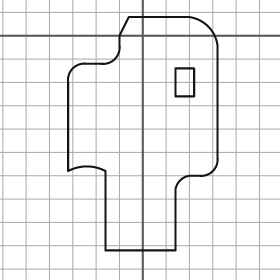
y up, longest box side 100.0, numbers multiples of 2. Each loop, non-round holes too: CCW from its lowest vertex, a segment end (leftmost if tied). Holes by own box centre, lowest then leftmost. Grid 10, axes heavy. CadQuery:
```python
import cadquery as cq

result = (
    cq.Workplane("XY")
    .moveTo(-16.0, -92.0)
    .lineTo(14.0, -92.0)
    .lineTo(14.0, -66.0)
    .threePointArc((16.0, -62.0), (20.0, -60.0))
    .lineTo(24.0, -60.0)
    .threePointArc((30.0, -58.0), (32.0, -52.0))
    .lineTo(32.0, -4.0)
    .threePointArc((28.0, 4.0), (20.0, 8.0))
    .lineTo(-6.0, 8.0)
    .lineTo(-10.0, 0.0)
    .lineTo(-10.0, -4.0)
    .threePointArc((-12.0, -10.0), (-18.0, -12.0))
    .lineTo(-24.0, -12.0)
    .threePointArc((-30.0, -14.0), (-32.0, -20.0))
    .lineTo(-32.0, -58.0)
    .threePointArc((-24.0, -56.0), (-16.0, -58.0))
    .close()
    .moveTo(14.0, -26.0)
    .lineTo(22.0, -26.0)
    .lineTo(22.0, -14.0)
    .lineTo(14.0, -14.0)
    .close()
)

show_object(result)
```